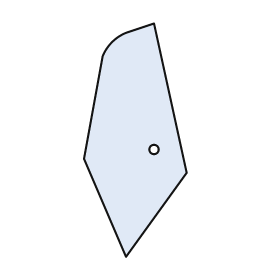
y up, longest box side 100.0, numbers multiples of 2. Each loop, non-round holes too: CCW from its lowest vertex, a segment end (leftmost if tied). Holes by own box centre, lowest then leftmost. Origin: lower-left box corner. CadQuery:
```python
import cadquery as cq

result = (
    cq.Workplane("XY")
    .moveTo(18.0, 0.0)
    .lineTo(44.0, 36.0)
    .lineTo(30.0, 100.0)
    .lineTo(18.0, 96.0)
    .threePointArc((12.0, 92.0), (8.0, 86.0))
    .lineTo(0.0, 42.0)
    .close()
    .moveTo(30.0, 46.0)
    .circle(2.0)
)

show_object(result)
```